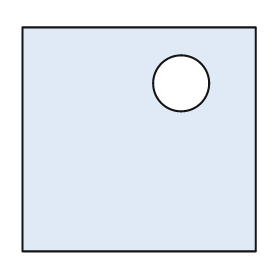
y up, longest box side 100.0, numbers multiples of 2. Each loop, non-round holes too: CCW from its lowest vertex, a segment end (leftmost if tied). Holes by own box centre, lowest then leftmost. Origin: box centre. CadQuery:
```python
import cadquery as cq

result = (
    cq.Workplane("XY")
    .moveTo(-50.0, -48.0)
    .lineTo(50.0, -48.0)
    .lineTo(50.0, 48.0)
    .lineTo(-50.0, 48.0)
    .close()
    .moveTo(18.0, 24.0)
    .circle(12.0)
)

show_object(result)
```